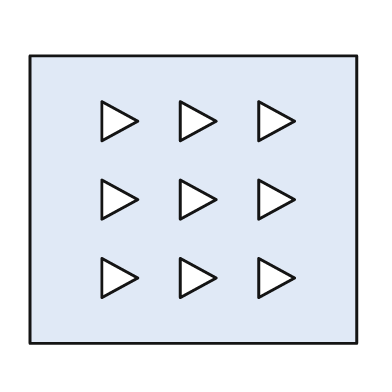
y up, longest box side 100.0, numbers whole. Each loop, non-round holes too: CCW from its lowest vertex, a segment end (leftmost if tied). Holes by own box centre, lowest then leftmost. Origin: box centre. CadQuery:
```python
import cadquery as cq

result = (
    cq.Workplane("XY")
    .moveTo(-50.0, -44.0)
    .lineTo(50.0, -44.0)
    .lineTo(50.0, 44.0)
    .lineTo(-50.0, 44.0)
    .close()
    .moveTo(-28.0, -30.0)
    .lineTo(-17.0, -24.0)
    .lineTo(-28.0, -18.0)
    .close()
    .moveTo(-4.0, -30.0)
    .lineTo(7.0, -24.0)
    .lineTo(-4.0, -18.0)
    .close()
    .moveTo(20.0, -30.0)
    .lineTo(31.0, -24.0)
    .lineTo(20.0, -18.0)
    .close()
    .moveTo(-28.0, -6.0)
    .lineTo(-17.0, 0.0)
    .lineTo(-28.0, 6.0)
    .close()
    .moveTo(-4.0, -6.0)
    .lineTo(7.0, 0.0)
    .lineTo(-4.0, 6.0)
    .close()
    .moveTo(20.0, -6.0)
    .lineTo(31.0, 0.0)
    .lineTo(20.0, 6.0)
    .close()
    .moveTo(-28.0, 18.0)
    .lineTo(-17.0, 24.0)
    .lineTo(-28.0, 30.0)
    .close()
    .moveTo(-4.0, 18.0)
    .lineTo(7.0, 24.0)
    .lineTo(-4.0, 30.0)
    .close()
    .moveTo(20.0, 18.0)
    .lineTo(31.0, 24.0)
    .lineTo(20.0, 30.0)
    .close()
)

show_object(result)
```